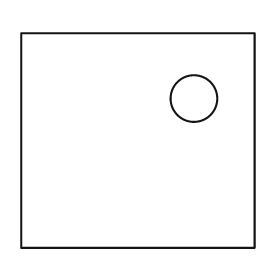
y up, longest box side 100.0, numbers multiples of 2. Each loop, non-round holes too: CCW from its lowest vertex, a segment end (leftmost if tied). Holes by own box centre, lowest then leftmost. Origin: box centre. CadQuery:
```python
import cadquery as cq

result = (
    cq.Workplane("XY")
    .moveTo(-50.0, -46.0)
    .lineTo(50.0, -46.0)
    .lineTo(50.0, 46.0)
    .lineTo(-50.0, 46.0)
    .close()
    .moveTo(24.0, 18.0)
    .circle(10.0)
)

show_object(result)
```